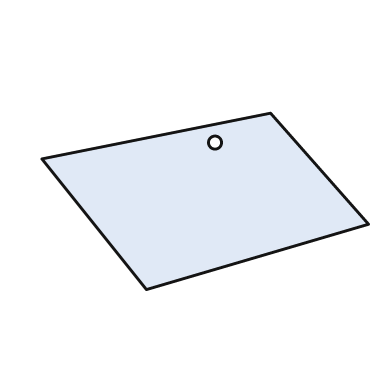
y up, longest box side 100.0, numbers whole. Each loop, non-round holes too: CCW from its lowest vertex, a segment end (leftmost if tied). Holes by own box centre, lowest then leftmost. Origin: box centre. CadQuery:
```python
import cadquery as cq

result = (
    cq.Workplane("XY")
    .moveTo(-18.0, -27.0)
    .lineTo(50.0, -7.0)
    .lineTo(20.0, 27.0)
    .lineTo(-50.0, 13.0)
    .close()
    .moveTo(3.0, 18.0)
    .circle(2.0)
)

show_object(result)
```